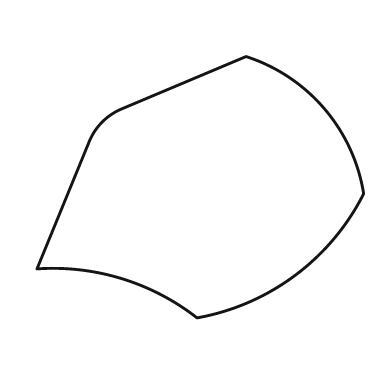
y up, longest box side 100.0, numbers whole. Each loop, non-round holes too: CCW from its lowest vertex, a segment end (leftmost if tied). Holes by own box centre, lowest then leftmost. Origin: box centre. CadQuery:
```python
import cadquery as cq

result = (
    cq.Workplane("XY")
    .moveTo(-1.0, -40.0)
    .threePointArc((29.0, -27.0), (50.0, -2.0))
    .threePointArc((38.0, 24.0), (14.0, 40.0))
    .lineTo(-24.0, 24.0)
    .threePointArc((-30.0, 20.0), (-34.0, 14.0))
    .lineTo(-50.0, -25.0)
    .threePointArc((-24.0, -28.0), (-1.0, -40.0))
    .close()
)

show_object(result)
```